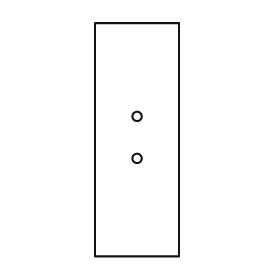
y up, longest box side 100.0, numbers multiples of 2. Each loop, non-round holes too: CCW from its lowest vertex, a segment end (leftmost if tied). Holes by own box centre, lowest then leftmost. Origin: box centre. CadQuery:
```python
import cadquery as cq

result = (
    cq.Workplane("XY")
    .moveTo(-18.0, -50.0)
    .lineTo(18.0, -50.0)
    .lineTo(18.0, 50.0)
    .lineTo(-18.0, 50.0)
    .close()
    .moveTo(0.0, -8.0)
    .circle(2.0)
    .moveTo(0.0, 10.0)
    .circle(2.0)
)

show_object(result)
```